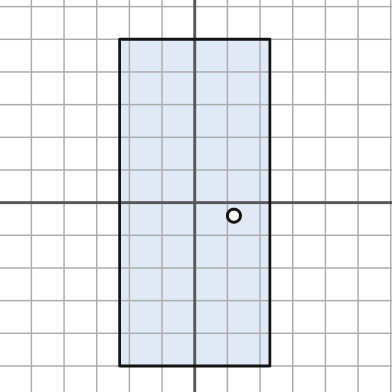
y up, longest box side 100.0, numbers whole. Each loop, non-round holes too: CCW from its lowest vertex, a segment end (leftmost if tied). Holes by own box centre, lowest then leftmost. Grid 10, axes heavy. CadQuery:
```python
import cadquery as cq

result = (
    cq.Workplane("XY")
    .moveTo(-23.0, -50.0)
    .lineTo(23.0, -50.0)
    .lineTo(23.0, 50.0)
    .lineTo(-23.0, 50.0)
    .close()
    .moveTo(12.0, -4.0)
    .circle(2.0)
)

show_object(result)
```